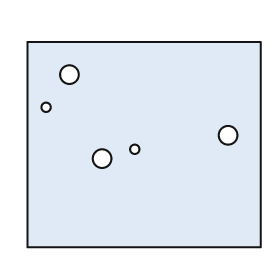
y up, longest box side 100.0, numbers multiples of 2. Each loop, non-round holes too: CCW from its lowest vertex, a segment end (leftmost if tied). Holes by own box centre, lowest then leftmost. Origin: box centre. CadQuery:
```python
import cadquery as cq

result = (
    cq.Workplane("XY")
    .moveTo(-50.0, -44.0)
    .lineTo(50.0, -44.0)
    .lineTo(50.0, 44.0)
    .lineTo(-50.0, 44.0)
    .close()
    .moveTo(-18.0, -6.0)
    .circle(4.0)
    .moveTo(-4.0, -2.0)
    .circle(2.0)
    .moveTo(36.0, 4.0)
    .circle(4.0)
    .moveTo(-42.0, 16.0)
    .circle(2.0)
    .moveTo(-32.0, 30.0)
    .circle(4.0)
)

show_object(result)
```